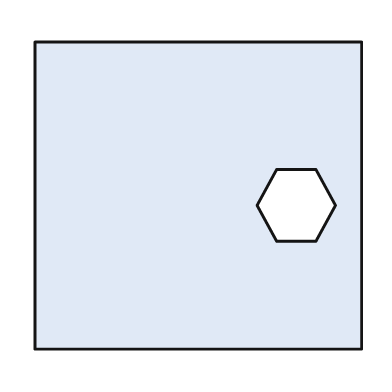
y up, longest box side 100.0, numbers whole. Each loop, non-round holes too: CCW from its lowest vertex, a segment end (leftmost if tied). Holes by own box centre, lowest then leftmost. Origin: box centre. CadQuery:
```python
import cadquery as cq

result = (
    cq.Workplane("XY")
    .moveTo(-50.0, -47.0)
    .lineTo(50.0, -47.0)
    .lineTo(50.0, 47.0)
    .lineTo(-50.0, 47.0)
    .close()
    .moveTo(24.0, -14.0)
    .lineTo(36.0, -14.0)
    .lineTo(42.0, -3.0)
    .lineTo(36.0, 8.0)
    .lineTo(24.0, 8.0)
    .lineTo(18.0, -3.0)
    .close()
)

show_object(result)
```